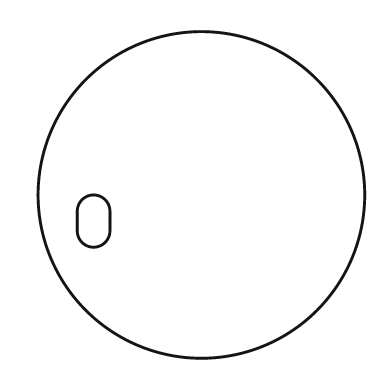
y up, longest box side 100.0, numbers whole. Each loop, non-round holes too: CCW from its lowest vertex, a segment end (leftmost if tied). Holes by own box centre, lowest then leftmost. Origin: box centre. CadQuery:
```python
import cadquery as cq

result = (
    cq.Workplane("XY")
    .moveTo(0.0, 0.0)
    .circle(50.0)
    .moveTo(-38.0, -11.0)
    .threePointArc((-33.0, -16.0), (-28.0, -11.0))
    .lineTo(-28.0, -5.0)
    .threePointArc((-33.0, 0.0), (-38.0, -5.0))
    .close()
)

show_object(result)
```